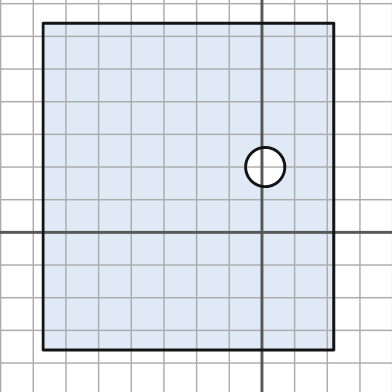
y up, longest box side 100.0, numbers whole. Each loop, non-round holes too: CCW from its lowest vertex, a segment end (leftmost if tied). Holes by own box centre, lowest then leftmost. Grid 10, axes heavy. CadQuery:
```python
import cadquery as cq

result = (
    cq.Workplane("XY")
    .moveTo(-67.0, -36.0)
    .lineTo(22.0, -36.0)
    .lineTo(22.0, 64.0)
    .lineTo(-67.0, 64.0)
    .close()
    .moveTo(1.0, 20.0)
    .circle(6.0)
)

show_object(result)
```